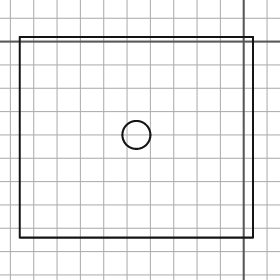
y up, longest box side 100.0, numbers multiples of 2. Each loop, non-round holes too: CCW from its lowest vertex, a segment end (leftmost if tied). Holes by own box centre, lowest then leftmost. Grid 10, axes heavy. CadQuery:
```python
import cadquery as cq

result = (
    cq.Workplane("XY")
    .moveTo(-96.0, -84.0)
    .lineTo(4.0, -84.0)
    .lineTo(4.0, 2.0)
    .lineTo(-96.0, 2.0)
    .close()
    .moveTo(-46.0, -40.0)
    .circle(6.0)
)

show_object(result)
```